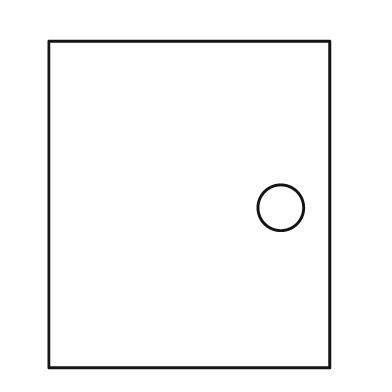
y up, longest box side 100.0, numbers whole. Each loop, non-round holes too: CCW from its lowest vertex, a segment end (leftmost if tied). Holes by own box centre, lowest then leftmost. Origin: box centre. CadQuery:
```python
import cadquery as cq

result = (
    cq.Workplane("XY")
    .moveTo(-43.0, -50.0)
    .lineTo(43.0, -50.0)
    .lineTo(43.0, 50.0)
    .lineTo(-43.0, 50.0)
    .close()
    .moveTo(28.0, -1.0)
    .circle(7.0)
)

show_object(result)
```